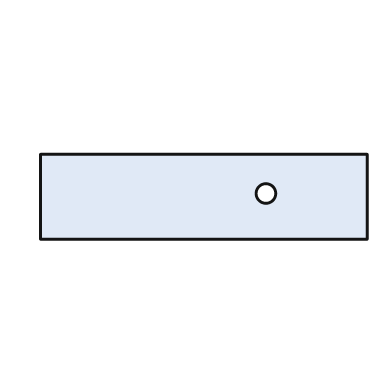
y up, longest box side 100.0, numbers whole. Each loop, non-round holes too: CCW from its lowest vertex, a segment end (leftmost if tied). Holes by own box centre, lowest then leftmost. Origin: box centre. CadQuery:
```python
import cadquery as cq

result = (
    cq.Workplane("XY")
    .moveTo(-50.0, -13.0)
    .lineTo(50.0, -13.0)
    .lineTo(50.0, 13.0)
    .lineTo(-50.0, 13.0)
    .close()
    .moveTo(19.0, 1.0)
    .circle(3.0)
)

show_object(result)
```